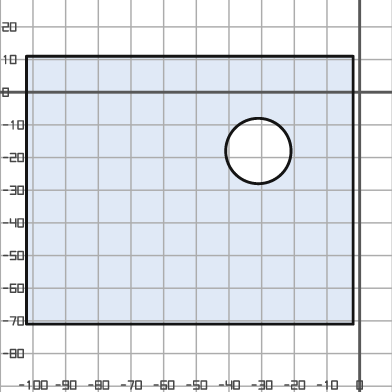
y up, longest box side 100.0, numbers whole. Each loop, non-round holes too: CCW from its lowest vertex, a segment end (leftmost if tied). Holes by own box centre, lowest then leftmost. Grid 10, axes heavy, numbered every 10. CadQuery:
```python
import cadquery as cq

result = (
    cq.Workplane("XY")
    .moveTo(-102.0, -71.0)
    .lineTo(-2.0, -71.0)
    .lineTo(-2.0, 11.0)
    .lineTo(-102.0, 11.0)
    .close()
    .moveTo(-31.0, -18.0)
    .circle(10.0)
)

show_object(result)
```